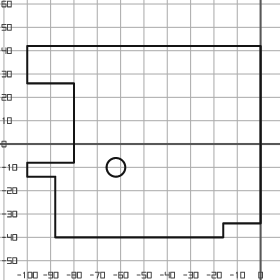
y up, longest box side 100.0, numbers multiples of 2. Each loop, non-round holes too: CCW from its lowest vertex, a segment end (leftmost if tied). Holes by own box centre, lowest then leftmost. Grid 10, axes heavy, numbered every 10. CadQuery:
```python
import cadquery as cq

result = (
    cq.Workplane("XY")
    .moveTo(-88.0, -40.0)
    .lineTo(-16.0, -40.0)
    .lineTo(-16.0, -34.0)
    .lineTo(0.0, -34.0)
    .lineTo(0.0, 42.0)
    .lineTo(-100.0, 42.0)
    .lineTo(-100.0, 26.0)
    .lineTo(-80.0, 26.0)
    .lineTo(-80.0, -8.0)
    .lineTo(-100.0, -8.0)
    .lineTo(-100.0, -14.0)
    .lineTo(-88.0, -14.0)
    .close()
    .moveTo(-62.0, -10.0)
    .circle(4.0)
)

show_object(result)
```